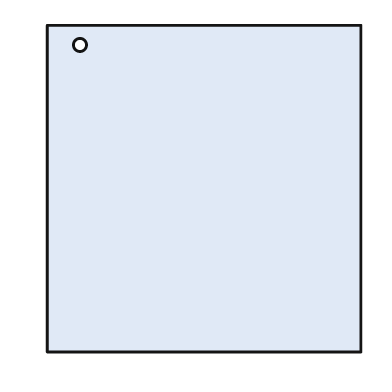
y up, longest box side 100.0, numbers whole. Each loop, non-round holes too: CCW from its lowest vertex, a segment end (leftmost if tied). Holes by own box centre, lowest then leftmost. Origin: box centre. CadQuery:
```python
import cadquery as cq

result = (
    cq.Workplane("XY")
    .moveTo(-48.0, -50.0)
    .lineTo(48.0, -50.0)
    .lineTo(48.0, 50.0)
    .lineTo(-48.0, 50.0)
    .close()
    .moveTo(-38.0, 44.0)
    .circle(2.0)
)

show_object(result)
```